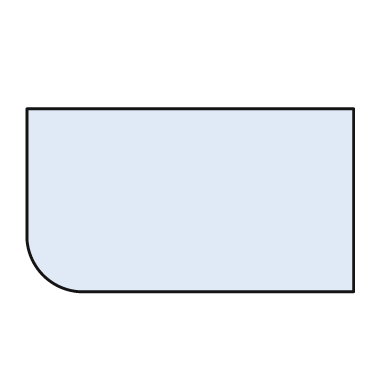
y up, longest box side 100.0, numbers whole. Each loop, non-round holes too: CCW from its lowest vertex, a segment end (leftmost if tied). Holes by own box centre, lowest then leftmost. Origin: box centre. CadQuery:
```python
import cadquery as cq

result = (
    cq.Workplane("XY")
    .moveTo(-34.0, -28.0)
    .lineTo(50.0, -28.0)
    .lineTo(50.0, 28.0)
    .lineTo(-50.0, 28.0)
    .lineTo(-50.0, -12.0)
    .threePointArc((-45.0, -23.0), (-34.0, -28.0))
    .close()
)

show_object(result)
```